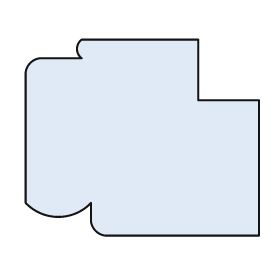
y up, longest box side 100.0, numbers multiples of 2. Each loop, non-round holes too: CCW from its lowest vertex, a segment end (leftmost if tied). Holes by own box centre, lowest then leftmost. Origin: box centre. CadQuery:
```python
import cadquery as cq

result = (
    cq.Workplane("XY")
    .moveTo(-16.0, -42.0)
    .lineTo(50.0, -42.0)
    .lineTo(50.0, 16.0)
    .lineTo(24.0, 16.0)
    .lineTo(24.0, 42.0)
    .lineTo(-26.0, 42.0)
    .threePointArc((-28.0, 38.0), (-26.0, 34.0))
    .lineTo(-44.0, 34.0)
    .threePointArc((-48.0, 32.0), (-50.0, 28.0))
    .lineTo(-50.0, -28.0)
    .threePointArc((-36.0, -34.0), (-22.0, -28.0))
    .lineTo(-22.0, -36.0)
    .threePointArc((-20.0, -40.0), (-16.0, -42.0))
    .close()
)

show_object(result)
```